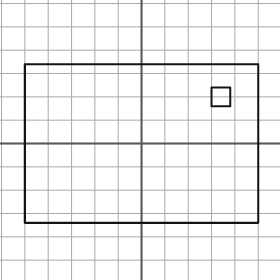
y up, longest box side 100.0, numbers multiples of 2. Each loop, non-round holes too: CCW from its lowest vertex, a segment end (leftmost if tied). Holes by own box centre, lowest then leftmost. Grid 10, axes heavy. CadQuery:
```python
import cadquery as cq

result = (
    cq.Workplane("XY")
    .moveTo(-50.0, -34.0)
    .lineTo(50.0, -34.0)
    .lineTo(50.0, 34.0)
    .lineTo(-50.0, 34.0)
    .close()
    .moveTo(30.0, 16.0)
    .lineTo(38.0, 16.0)
    .lineTo(38.0, 24.0)
    .lineTo(30.0, 24.0)
    .close()
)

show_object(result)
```